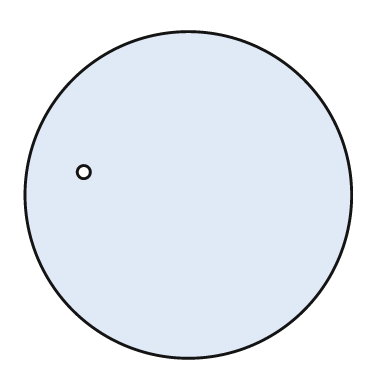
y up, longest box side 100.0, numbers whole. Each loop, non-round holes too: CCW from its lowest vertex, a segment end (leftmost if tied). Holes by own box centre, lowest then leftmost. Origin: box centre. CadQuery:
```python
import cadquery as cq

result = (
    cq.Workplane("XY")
    .moveTo(0.0, 0.0)
    .circle(50.0)
    .moveTo(-32.0, 7.0)
    .circle(2.0)
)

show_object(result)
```